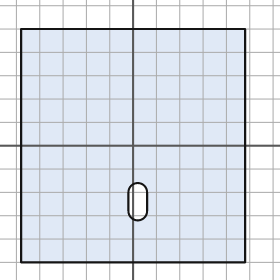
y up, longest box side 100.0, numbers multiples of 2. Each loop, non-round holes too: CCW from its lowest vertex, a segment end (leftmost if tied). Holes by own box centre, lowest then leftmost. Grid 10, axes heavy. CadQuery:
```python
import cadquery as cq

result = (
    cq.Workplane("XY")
    .moveTo(-48.0, -50.0)
    .lineTo(48.0, -50.0)
    .lineTo(48.0, 50.0)
    .lineTo(-48.0, 50.0)
    .close()
    .moveTo(-2.0, -28.0)
    .threePointArc((2.0, -32.0), (6.0, -28.0))
    .lineTo(6.0, -20.0)
    .threePointArc((2.0, -16.0), (-2.0, -20.0))
    .close()
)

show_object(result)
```